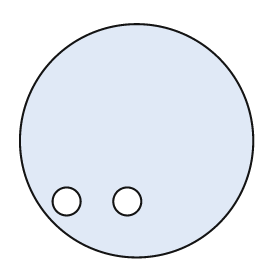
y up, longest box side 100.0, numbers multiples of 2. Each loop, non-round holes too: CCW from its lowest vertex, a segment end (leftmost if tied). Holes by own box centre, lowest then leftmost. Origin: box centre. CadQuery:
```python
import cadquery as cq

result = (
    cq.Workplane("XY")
    .moveTo(0.0, 0.0)
    .circle(50.0)
    .moveTo(-30.0, -26.0)
    .circle(6.0)
    .moveTo(-4.0, -26.0)
    .circle(6.0)
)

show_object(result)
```